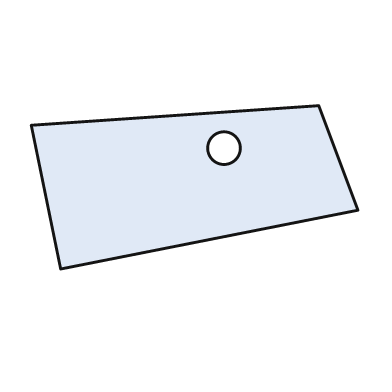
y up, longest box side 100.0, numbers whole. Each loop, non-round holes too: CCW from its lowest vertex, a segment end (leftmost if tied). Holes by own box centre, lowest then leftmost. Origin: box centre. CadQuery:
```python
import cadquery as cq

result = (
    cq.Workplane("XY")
    .moveTo(-41.0, -25.0)
    .lineTo(50.0, -7.0)
    .lineTo(38.0, 25.0)
    .lineTo(-50.0, 19.0)
    .close()
    .moveTo(9.0, 12.0)
    .circle(5.0)
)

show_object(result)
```